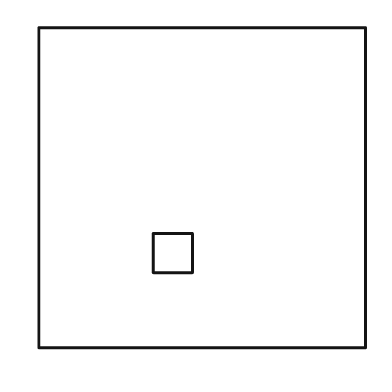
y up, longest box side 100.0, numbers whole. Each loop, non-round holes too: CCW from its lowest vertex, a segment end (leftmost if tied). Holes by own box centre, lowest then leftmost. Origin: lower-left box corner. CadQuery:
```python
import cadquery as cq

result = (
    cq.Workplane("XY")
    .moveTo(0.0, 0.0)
    .lineTo(100.0, 0.0)
    .lineTo(100.0, 98.0)
    .lineTo(0.0, 98.0)
    .close()
    .moveTo(35.0, 23.0)
    .lineTo(47.0, 23.0)
    .lineTo(47.0, 35.0)
    .lineTo(35.0, 35.0)
    .close()
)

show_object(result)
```